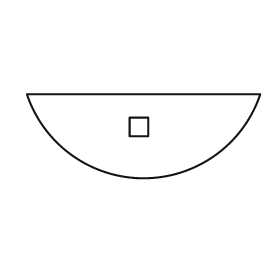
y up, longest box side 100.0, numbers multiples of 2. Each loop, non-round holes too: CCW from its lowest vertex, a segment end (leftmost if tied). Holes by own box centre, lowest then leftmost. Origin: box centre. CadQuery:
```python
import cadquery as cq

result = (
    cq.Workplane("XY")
    .moveTo(-50.0, 18.0)
    .threePointArc((0.0, -18.0), (50.0, 18.0))
    .close()
    .moveTo(-6.0, 0.0)
    .lineTo(2.0, 0.0)
    .lineTo(2.0, 8.0)
    .lineTo(-6.0, 8.0)
    .close()
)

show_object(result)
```